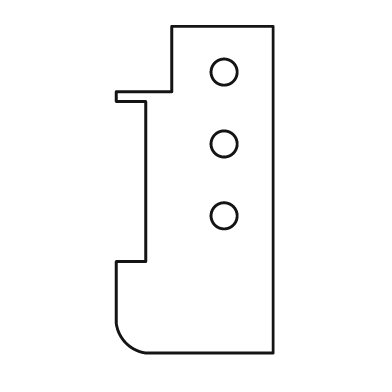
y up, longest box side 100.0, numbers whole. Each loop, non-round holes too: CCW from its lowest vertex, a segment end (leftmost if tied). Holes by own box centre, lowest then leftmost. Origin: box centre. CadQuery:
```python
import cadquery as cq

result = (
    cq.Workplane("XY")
    .moveTo(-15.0, -50.0)
    .lineTo(24.0, -50.0)
    .lineTo(24.0, 50.0)
    .lineTo(-7.0, 50.0)
    .lineTo(-7.0, 30.0)
    .lineTo(-24.0, 30.0)
    .lineTo(-24.0, 27.0)
    .lineTo(-15.0, 27.0)
    .lineTo(-15.0, -22.0)
    .lineTo(-24.0, -22.0)
    .lineTo(-24.0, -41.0)
    .threePointArc((-21.0, -47.0), (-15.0, -50.0))
    .close()
    .moveTo(9.0, -8.0)
    .circle(4.0)
    .moveTo(9.0, 14.0)
    .circle(4.0)
    .moveTo(9.0, 36.0)
    .circle(4.0)
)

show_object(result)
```